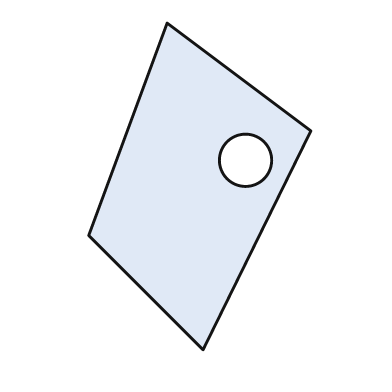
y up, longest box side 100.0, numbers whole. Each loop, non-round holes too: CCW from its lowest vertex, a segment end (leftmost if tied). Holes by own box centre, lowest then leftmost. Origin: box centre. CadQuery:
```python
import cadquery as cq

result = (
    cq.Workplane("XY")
    .moveTo(1.0, -50.0)
    .lineTo(34.0, 17.0)
    .lineTo(-10.0, 50.0)
    .lineTo(-34.0, -15.0)
    .close()
    .moveTo(14.0, 8.0)
    .circle(8.0)
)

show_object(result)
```